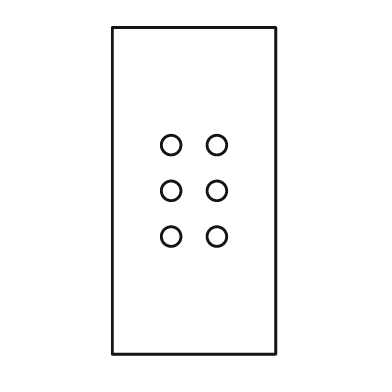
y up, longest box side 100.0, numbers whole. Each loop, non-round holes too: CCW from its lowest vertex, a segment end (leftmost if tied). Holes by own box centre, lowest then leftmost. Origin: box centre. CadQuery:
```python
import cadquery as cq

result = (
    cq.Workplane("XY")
    .moveTo(-25.0, -50.0)
    .lineTo(25.0, -50.0)
    .lineTo(25.0, 50.0)
    .lineTo(-25.0, 50.0)
    .close()
    .moveTo(-7.0, -14.0)
    .circle(3.0)
    .moveTo(7.0, -14.0)
    .circle(3.0)
    .moveTo(-7.0, 0.0)
    .circle(3.0)
    .moveTo(7.0, 0.0)
    .circle(3.0)
    .moveTo(-7.0, 14.0)
    .circle(3.0)
    .moveTo(7.0, 14.0)
    .circle(3.0)
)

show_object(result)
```